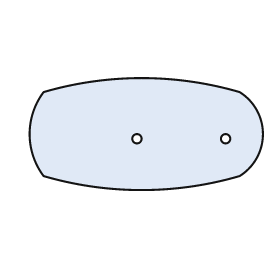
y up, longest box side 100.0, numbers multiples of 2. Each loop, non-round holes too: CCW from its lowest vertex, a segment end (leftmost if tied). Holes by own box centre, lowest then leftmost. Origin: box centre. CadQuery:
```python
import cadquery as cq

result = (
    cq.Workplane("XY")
    .moveTo(-44.0, -18.0)
    .threePointArc((-2.0, -24.0), (40.0, -18.0))
    .threePointArc((50.0, 0.0), (40.0, 18.0))
    .threePointArc((-2.0, 24.0), (-44.0, 18.0))
    .threePointArc((-50.0, 0.0), (-44.0, -18.0))
    .close()
    .moveTo(-4.0, -2.0)
    .circle(2.0)
    .moveTo(34.0, -2.0)
    .circle(2.0)
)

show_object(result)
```